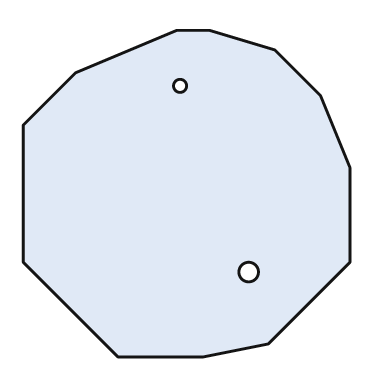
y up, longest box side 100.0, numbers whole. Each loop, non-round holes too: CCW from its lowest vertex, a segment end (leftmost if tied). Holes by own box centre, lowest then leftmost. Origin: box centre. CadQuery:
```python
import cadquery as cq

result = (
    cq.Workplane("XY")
    .moveTo(-21.0, -50.0)
    .lineTo(5.0, -50.0)
    .lineTo(25.0, -46.0)
    .lineTo(50.0, -21.0)
    .lineTo(50.0, 8.0)
    .lineTo(41.0, 30.0)
    .lineTo(27.0, 44.0)
    .lineTo(7.0, 50.0)
    .lineTo(-3.0, 50.0)
    .lineTo(-34.0, 37.0)
    .lineTo(-50.0, 21.0)
    .lineTo(-50.0, -21.0)
    .close()
    .moveTo(19.0, -24.0)
    .circle(3.0)
    .moveTo(-2.0, 33.0)
    .circle(2.0)
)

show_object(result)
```